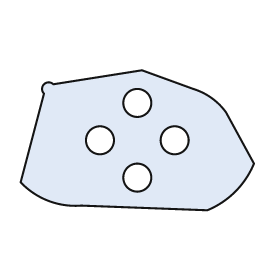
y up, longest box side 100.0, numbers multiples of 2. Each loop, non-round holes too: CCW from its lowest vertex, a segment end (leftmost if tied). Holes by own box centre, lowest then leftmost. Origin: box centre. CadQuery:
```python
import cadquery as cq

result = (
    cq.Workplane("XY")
    .moveTo(30.0, -30.0)
    .threePointArc((42.0, -22.0), (50.0, -10.0))
    .lineTo(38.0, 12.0)
    .threePointArc((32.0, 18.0), (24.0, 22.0))
    .lineTo(2.0, 30.0)
    .lineTo(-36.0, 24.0)
    .threePointArc((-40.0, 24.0), (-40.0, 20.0))
    .lineTo(-50.0, -18.0)
    .threePointArc((-38.0, -26.0), (-24.0, -28.0))
    .close()
    .moveTo(0.0, -16.0)
    .circle(6.0)
    .moveTo(-16.0, 0.0)
    .circle(6.0)
    .moveTo(16.0, 0.0)
    .circle(6.0)
    .moveTo(0.0, 16.0)
    .circle(6.0)
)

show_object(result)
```